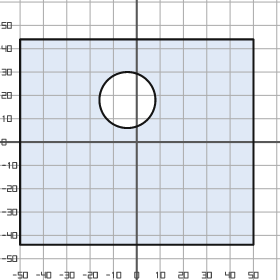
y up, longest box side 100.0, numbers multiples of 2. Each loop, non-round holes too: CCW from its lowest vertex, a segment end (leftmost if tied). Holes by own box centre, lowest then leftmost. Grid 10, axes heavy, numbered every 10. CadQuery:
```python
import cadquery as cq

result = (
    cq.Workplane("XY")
    .moveTo(-50.0, -44.0)
    .lineTo(50.0, -44.0)
    .lineTo(50.0, 44.0)
    .lineTo(-50.0, 44.0)
    .close()
    .moveTo(-4.0, 18.0)
    .circle(12.0)
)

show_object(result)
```